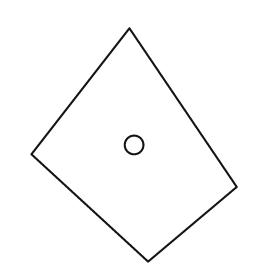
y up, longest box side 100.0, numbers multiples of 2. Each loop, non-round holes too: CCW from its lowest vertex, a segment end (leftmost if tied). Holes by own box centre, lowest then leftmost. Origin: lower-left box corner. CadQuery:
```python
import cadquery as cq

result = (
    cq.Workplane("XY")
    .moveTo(50.0, 0.0)
    .lineTo(88.0, 32.0)
    .lineTo(42.0, 100.0)
    .lineTo(0.0, 46.0)
    .close()
    .moveTo(44.0, 50.0)
    .circle(4.0)
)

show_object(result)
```